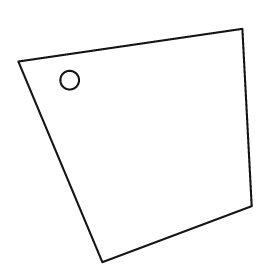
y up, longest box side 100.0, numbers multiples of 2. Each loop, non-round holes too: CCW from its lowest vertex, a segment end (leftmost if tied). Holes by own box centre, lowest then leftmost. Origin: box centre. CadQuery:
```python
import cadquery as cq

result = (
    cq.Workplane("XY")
    .moveTo(-14.0, -50.0)
    .lineTo(50.0, -26.0)
    .lineTo(46.0, 50.0)
    .lineTo(-50.0, 36.0)
    .close()
    .moveTo(-28.0, 28.0)
    .circle(4.0)
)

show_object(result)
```